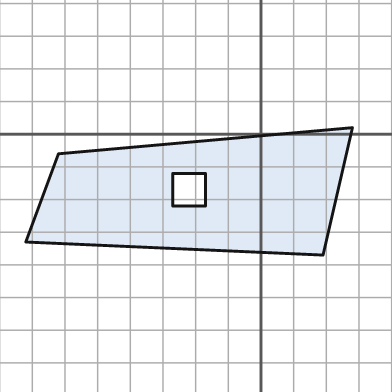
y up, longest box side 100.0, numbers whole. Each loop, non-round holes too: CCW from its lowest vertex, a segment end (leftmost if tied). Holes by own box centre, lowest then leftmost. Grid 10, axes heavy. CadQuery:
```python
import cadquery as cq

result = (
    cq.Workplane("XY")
    .moveTo(19.0, -37.0)
    .lineTo(28.0, 2.0)
    .lineTo(-62.0, -6.0)
    .lineTo(-72.0, -33.0)
    .close()
    .moveTo(-27.0, -22.0)
    .lineTo(-17.0, -22.0)
    .lineTo(-17.0, -12.0)
    .lineTo(-27.0, -12.0)
    .close()
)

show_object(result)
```